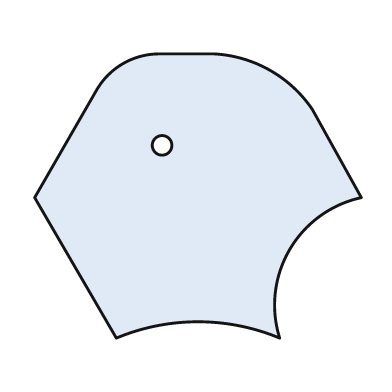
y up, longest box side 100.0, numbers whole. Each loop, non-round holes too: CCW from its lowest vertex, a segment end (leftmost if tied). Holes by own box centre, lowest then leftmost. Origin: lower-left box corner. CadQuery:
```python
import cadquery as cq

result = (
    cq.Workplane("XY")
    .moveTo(25.0, 0.0)
    .threePointArc((50.0, 5.0), (75.0, 0.0))
    .threePointArc((78.0, 27.0), (100.0, 43.0))
    .lineTo(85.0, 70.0)
    .threePointArc((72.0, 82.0), (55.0, 87.0))
    .lineTo(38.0, 87.0)
    .threePointArc((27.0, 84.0), (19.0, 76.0))
    .lineTo(0.0, 43.0)
    .close()
    .moveTo(39.0, 59.0)
    .circle(3.0)
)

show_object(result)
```